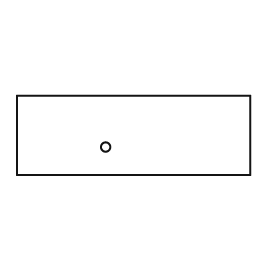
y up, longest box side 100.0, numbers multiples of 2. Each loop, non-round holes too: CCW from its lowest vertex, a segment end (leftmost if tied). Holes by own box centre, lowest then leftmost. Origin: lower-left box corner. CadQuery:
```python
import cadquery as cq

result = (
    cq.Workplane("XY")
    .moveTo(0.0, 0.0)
    .lineTo(100.0, 0.0)
    .lineTo(100.0, 34.0)
    .lineTo(0.0, 34.0)
    .close()
    .moveTo(38.0, 12.0)
    .circle(2.0)
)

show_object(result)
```